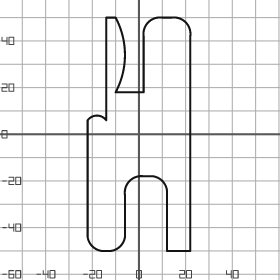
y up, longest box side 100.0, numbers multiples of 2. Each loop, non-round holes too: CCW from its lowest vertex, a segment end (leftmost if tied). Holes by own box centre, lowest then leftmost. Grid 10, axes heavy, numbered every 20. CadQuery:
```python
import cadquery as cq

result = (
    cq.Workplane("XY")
    .moveTo(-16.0, -50.0)
    .lineTo(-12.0, -50.0)
    .threePointArc((-8.0, -48.0), (-6.0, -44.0))
    .lineTo(-6.0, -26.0)
    .threePointArc((-4.0, -20.0), (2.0, -18.0))
    .lineTo(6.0, -18.0)
    .threePointArc((10.0, -20.0), (12.0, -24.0))
    .lineTo(12.0, -50.0)
    .lineTo(22.0, -50.0)
    .lineTo(22.0, 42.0)
    .threePointArc((20.0, 48.0), (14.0, 50.0))
    .lineTo(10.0, 50.0)
    .threePointArc((4.0, 48.0), (2.0, 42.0))
    .lineTo(2.0, 18.0)
    .lineTo(-10.0, 18.0)
    .threePointArc((-6.0, 34.0), (-10.0, 50.0))
    .lineTo(-14.0, 50.0)
    .lineTo(-14.0, 6.0)
    .threePointArc((-18.0, 8.0), (-22.0, 6.0))
    .lineTo(-22.0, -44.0)
    .threePointArc((-20.0, -48.0), (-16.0, -50.0))
    .close()
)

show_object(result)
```